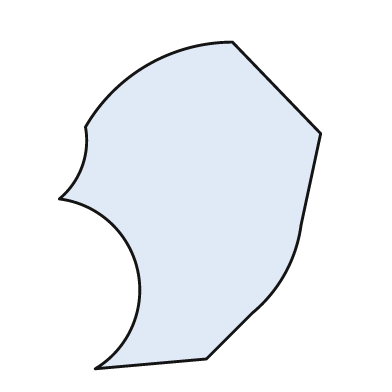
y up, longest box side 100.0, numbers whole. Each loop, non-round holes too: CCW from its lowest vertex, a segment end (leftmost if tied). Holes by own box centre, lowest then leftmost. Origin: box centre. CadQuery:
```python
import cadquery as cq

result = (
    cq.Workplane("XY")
    .moveTo(-29.0, -50.0)
    .lineTo(5.0, -47.0)
    .lineTo(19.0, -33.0)
    .threePointArc((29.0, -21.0), (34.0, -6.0))
    .lineTo(40.0, 22.0)
    .lineTo(13.0, 50.0)
    .threePointArc((-13.0, 43.0), (-32.0, 24.0))
    .threePointArc((-33.0, 12.0), (-40.0, 2.0))
    .threePointArc((-16.0, -20.0), (-29.0, -50.0))
    .close()
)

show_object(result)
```